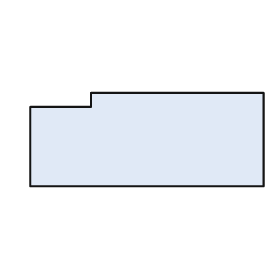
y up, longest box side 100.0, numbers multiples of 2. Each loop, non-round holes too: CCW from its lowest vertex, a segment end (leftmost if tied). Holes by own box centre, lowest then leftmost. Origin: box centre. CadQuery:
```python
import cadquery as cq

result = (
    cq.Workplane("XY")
    .moveTo(-50.0, -20.0)
    .lineTo(50.0, -20.0)
    .lineTo(50.0, 20.0)
    .lineTo(-24.0, 20.0)
    .lineTo(-24.0, 14.0)
    .lineTo(-50.0, 14.0)
    .close()
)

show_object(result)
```